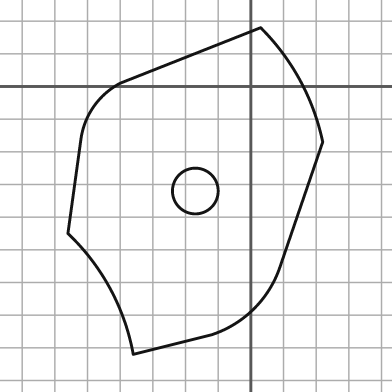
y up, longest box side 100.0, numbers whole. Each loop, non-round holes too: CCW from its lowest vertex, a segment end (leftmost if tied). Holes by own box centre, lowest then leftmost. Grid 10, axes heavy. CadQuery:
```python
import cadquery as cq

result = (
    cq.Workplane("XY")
    .moveTo(-36.0, -82.0)
    .lineTo(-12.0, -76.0)
    .threePointArc((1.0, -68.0), (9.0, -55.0))
    .lineTo(22.0, -17.0)
    .threePointArc((15.0, 2.0), (3.0, 18.0))
    .lineTo(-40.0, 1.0)
    .threePointArc((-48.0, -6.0), (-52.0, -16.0))
    .lineTo(-56.0, -45.0)
    .threePointArc((-43.0, -62.0), (-36.0, -82.0))
    .close()
    .moveTo(-17.0, -32.0)
    .circle(7.0)
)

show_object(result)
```